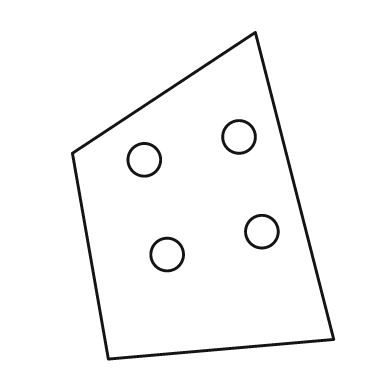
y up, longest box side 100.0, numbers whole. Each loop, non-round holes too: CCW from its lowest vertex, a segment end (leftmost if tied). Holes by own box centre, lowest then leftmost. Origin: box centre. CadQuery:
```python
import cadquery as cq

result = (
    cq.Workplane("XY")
    .moveTo(-29.0, -50.0)
    .lineTo(40.0, -44.0)
    .lineTo(16.0, 50.0)
    .lineTo(-40.0, 13.0)
    .close()
    .moveTo(-11.0, -18.0)
    .circle(5.0)
    .moveTo(18.0, -11.0)
    .circle(5.0)
    .moveTo(-18.0, 11.0)
    .circle(5.0)
    .moveTo(11.0, 18.0)
    .circle(5.0)
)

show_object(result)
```